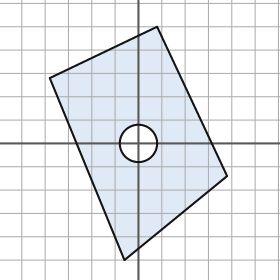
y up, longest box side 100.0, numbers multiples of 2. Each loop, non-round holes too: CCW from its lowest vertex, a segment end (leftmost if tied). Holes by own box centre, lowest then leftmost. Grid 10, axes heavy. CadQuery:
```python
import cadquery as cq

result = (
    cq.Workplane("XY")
    .moveTo(-6.0, -50.0)
    .lineTo(38.0, -14.0)
    .lineTo(8.0, 50.0)
    .lineTo(-38.0, 28.0)
    .close()
    .moveTo(0.0, 0.0)
    .circle(8.0)
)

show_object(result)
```